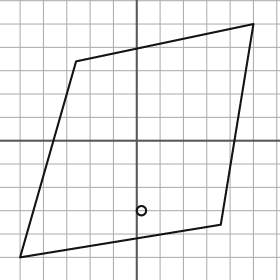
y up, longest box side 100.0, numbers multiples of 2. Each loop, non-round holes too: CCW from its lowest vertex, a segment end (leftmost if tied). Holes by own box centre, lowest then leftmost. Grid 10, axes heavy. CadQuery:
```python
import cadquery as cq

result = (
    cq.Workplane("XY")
    .moveTo(-50.0, -50.0)
    .lineTo(36.0, -36.0)
    .lineTo(50.0, 50.0)
    .lineTo(-26.0, 34.0)
    .close()
    .moveTo(2.0, -30.0)
    .circle(2.0)
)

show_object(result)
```